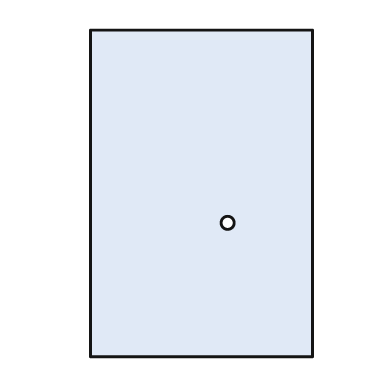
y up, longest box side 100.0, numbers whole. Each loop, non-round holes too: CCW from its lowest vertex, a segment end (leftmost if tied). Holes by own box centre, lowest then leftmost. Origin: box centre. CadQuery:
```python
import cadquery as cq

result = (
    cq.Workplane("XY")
    .moveTo(-34.0, -50.0)
    .lineTo(34.0, -50.0)
    .lineTo(34.0, 50.0)
    .lineTo(-34.0, 50.0)
    .close()
    .moveTo(8.0, -9.0)
    .circle(2.0)
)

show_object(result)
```